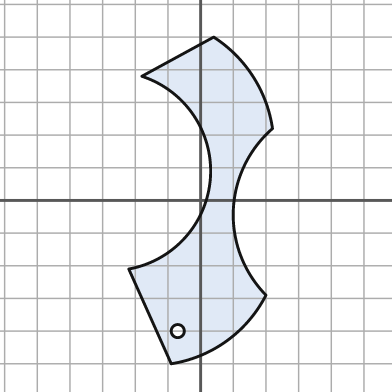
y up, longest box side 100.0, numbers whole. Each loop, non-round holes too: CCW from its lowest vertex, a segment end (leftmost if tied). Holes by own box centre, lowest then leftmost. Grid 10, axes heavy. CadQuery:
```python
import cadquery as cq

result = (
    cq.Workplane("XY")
    .moveTo(-9.0, -50.0)
    .threePointArc((8.0, -43.0), (20.0, -29.0))
    .threePointArc((10.0, -3.0), (22.0, 22.0))
    .threePointArc((16.0, 38.0), (4.0, 50.0))
    .lineTo(-18.0, 38.0)
    .threePointArc((3.0, 7.0), (-22.0, -21.0))
    .close()
    .moveTo(-7.0, -40.0)
    .circle(2.0)
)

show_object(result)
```